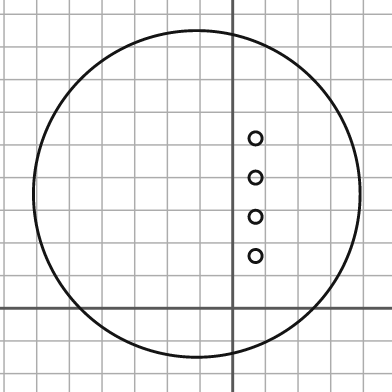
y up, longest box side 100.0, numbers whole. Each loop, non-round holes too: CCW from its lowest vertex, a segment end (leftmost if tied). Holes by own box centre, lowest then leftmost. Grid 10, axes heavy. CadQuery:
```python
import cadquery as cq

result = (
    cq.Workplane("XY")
    .moveTo(-11.0, 35.0)
    .circle(50.0)
    .moveTo(7.0, 16.0)
    .circle(2.0)
    .moveTo(7.0, 28.0)
    .circle(2.0)
    .moveTo(7.0, 40.0)
    .circle(2.0)
    .moveTo(7.0, 52.0)
    .circle(2.0)
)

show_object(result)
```